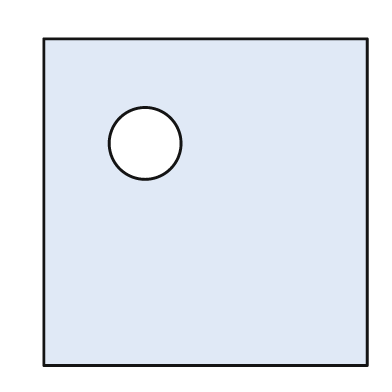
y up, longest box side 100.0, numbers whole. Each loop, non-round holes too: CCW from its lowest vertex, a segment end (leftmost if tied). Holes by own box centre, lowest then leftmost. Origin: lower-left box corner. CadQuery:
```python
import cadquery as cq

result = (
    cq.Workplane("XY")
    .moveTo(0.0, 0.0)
    .lineTo(99.0, 0.0)
    .lineTo(99.0, 100.0)
    .lineTo(0.0, 100.0)
    .close()
    .moveTo(31.0, 68.0)
    .circle(11.0)
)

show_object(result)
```